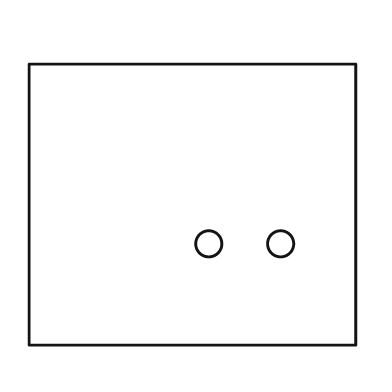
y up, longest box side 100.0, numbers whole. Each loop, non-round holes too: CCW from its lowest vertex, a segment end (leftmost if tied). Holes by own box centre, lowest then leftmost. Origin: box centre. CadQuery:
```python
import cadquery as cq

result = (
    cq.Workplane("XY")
    .moveTo(-50.0, -43.0)
    .lineTo(50.0, -43.0)
    .lineTo(50.0, 43.0)
    .lineTo(-50.0, 43.0)
    .close()
    .moveTo(5.0, -12.0)
    .circle(4.0)
    .moveTo(27.0, -12.0)
    .circle(4.0)
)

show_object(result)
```